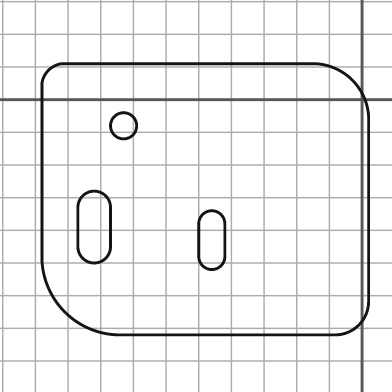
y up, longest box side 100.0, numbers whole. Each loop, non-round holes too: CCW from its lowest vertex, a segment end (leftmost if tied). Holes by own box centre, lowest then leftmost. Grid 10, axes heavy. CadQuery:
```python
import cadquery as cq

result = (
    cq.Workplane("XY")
    .moveTo(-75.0, -72.0)
    .lineTo(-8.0, -72.0)
    .threePointArc((-1.0, -69.0), (2.0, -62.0))
    .lineTo(2.0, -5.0)
    .threePointArc((-3.0, 6.0), (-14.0, 11.0))
    .lineTo(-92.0, 11.0)
    .threePointArc((-96.0, 9.0), (-98.0, 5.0))
    .lineTo(-98.0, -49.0)
    .threePointArc((-91.0, -65.0), (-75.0, -72.0))
    .close()
    .moveTo(-50.0, -48.0)
    .threePointArc((-46.0, -52.0), (-42.0, -48.0))
    .lineTo(-42.0, -38.0)
    .threePointArc((-46.0, -34.0), (-50.0, -38.0))
    .close()
    .moveTo(-87.0, -45.0)
    .threePointArc((-82.0, -50.0), (-77.0, -45.0))
    .lineTo(-77.0, -33.0)
    .threePointArc((-82.0, -28.0), (-87.0, -33.0))
    .close()
    .moveTo(-73.0, -8.0)
    .circle(4.0)
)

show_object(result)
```